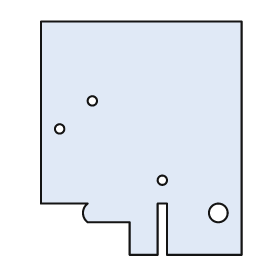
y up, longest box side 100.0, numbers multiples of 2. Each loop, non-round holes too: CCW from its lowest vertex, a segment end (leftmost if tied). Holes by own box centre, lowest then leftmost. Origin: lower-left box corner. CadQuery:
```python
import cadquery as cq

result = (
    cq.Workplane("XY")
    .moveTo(38.0, 0.0)
    .lineTo(50.0, 0.0)
    .lineTo(50.0, 22.0)
    .lineTo(54.0, 22.0)
    .lineTo(54.0, 0.0)
    .lineTo(86.0, 0.0)
    .lineTo(86.0, 100.0)
    .lineTo(0.0, 100.0)
    .lineTo(0.0, 22.0)
    .lineTo(20.0, 22.0)
    .threePointArc((18.0, 18.0), (20.0, 14.0))
    .lineTo(38.0, 14.0)
    .close()
    .moveTo(76.0, 18.0)
    .circle(4.0)
    .moveTo(52.0, 32.0)
    .circle(2.0)
    .moveTo(8.0, 54.0)
    .circle(2.0)
    .moveTo(22.0, 66.0)
    .circle(2.0)
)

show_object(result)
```